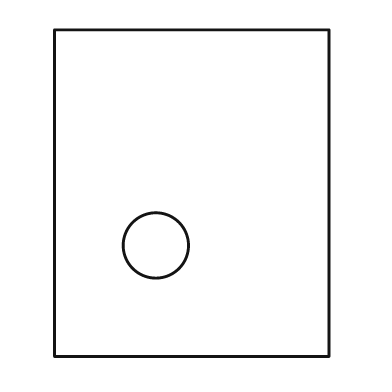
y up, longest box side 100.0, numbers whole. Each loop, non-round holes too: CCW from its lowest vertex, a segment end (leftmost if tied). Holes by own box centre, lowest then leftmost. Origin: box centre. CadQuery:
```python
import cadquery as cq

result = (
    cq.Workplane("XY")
    .moveTo(-42.0, -50.0)
    .lineTo(42.0, -50.0)
    .lineTo(42.0, 50.0)
    .lineTo(-42.0, 50.0)
    .close()
    .moveTo(-11.0, -16.0)
    .circle(10.0)
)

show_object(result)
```